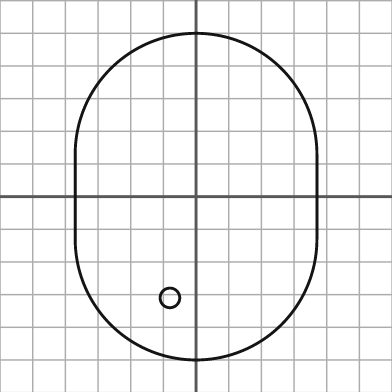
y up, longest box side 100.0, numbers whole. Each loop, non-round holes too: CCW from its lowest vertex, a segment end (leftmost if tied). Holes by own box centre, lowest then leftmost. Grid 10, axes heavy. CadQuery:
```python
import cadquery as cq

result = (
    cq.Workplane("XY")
    .moveTo(-37.0, -13.0)
    .threePointArc((0.0, -50.0), (37.0, -13.0))
    .lineTo(37.0, 13.0)
    .threePointArc((0.0, 50.0), (-37.0, 13.0))
    .close()
    .moveTo(-8.0, -31.0)
    .circle(3.0)
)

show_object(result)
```